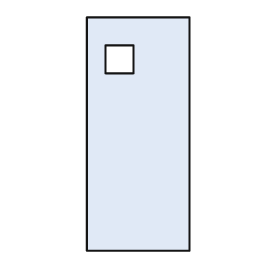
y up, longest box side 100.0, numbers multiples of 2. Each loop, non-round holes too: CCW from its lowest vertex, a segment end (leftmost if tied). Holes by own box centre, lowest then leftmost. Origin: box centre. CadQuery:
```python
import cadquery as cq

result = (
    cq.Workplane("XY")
    .moveTo(-22.0, -50.0)
    .lineTo(22.0, -50.0)
    .lineTo(22.0, 50.0)
    .lineTo(-22.0, 50.0)
    .close()
    .moveTo(-14.0, 26.0)
    .lineTo(-2.0, 26.0)
    .lineTo(-2.0, 38.0)
    .lineTo(-14.0, 38.0)
    .close()
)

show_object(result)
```